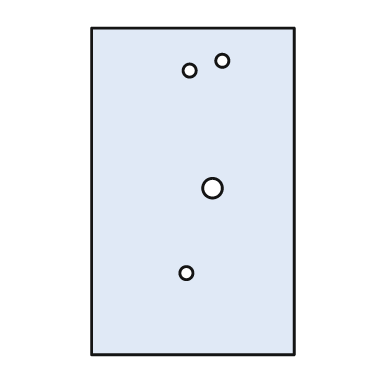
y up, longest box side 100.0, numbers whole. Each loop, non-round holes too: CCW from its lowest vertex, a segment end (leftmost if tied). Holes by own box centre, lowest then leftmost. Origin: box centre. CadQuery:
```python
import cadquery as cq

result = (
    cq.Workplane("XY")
    .moveTo(-31.0, -50.0)
    .lineTo(31.0, -50.0)
    .lineTo(31.0, 50.0)
    .lineTo(-31.0, 50.0)
    .close()
    .moveTo(-2.0, -25.0)
    .circle(2.0)
    .moveTo(6.0, 1.0)
    .circle(3.0)
    .moveTo(-1.0, 37.0)
    .circle(2.0)
    .moveTo(9.0, 40.0)
    .circle(2.0)
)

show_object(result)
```